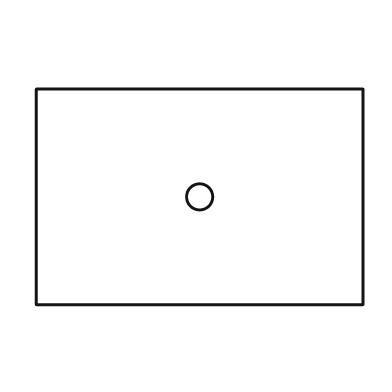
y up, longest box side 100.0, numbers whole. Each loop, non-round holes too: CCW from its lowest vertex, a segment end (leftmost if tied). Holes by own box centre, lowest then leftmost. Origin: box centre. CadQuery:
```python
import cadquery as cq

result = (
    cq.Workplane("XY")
    .moveTo(-50.0, -33.0)
    .lineTo(50.0, -33.0)
    .lineTo(50.0, 33.0)
    .lineTo(-50.0, 33.0)
    .close()
    .moveTo(0.0, 0.0)
    .circle(4.0)
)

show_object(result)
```